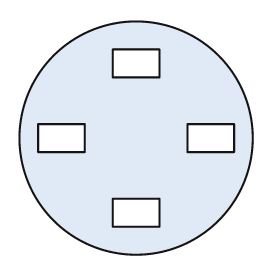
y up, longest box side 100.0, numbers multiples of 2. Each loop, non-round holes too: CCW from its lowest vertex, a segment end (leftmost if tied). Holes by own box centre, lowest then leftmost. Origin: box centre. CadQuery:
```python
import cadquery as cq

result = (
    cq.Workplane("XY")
    .moveTo(0.0, 0.0)
    .circle(50.0)
    .moveTo(-10.0, -38.0)
    .lineTo(10.0, -38.0)
    .lineTo(10.0, -26.0)
    .lineTo(-10.0, -26.0)
    .close()
    .moveTo(-42.0, -6.0)
    .lineTo(-22.0, -6.0)
    .lineTo(-22.0, 6.0)
    .lineTo(-42.0, 6.0)
    .close()
    .moveTo(22.0, -6.0)
    .lineTo(42.0, -6.0)
    .lineTo(42.0, 6.0)
    .lineTo(22.0, 6.0)
    .close()
    .moveTo(-10.0, 26.0)
    .lineTo(10.0, 26.0)
    .lineTo(10.0, 38.0)
    .lineTo(-10.0, 38.0)
    .close()
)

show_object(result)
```